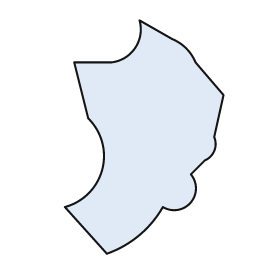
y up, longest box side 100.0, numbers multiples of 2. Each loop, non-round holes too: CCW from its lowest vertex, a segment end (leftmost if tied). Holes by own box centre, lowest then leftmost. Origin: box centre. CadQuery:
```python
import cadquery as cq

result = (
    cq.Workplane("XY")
    .moveTo(-16.0, -50.0)
    .threePointArc((-2.0, -42.0), (8.0, -30.0))
    .threePointArc((20.0, -28.0), (20.0, -16.0))
    .lineTo(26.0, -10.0)
    .threePointArc((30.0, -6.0), (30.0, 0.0))
    .lineTo(34.0, 18.0)
    .lineTo(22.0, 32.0)
    .threePointArc((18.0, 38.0), (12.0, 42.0))
    .lineTo(-2.0, 50.0)
    .threePointArc((-4.0, 38.0), (-14.0, 32.0))
    .lineTo(-30.0, 32.0)
    .lineTo(-24.0, 8.0)
    .threePointArc((-18.0, -14.0), (-34.0, -30.0))
    .close()
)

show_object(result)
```